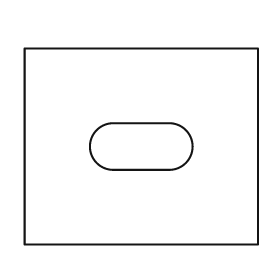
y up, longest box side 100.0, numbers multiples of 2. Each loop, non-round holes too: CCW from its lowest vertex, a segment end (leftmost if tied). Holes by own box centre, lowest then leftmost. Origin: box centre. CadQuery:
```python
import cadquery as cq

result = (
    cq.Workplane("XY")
    .moveTo(-50.0, -42.0)
    .lineTo(50.0, -42.0)
    .lineTo(50.0, 42.0)
    .lineTo(-50.0, 42.0)
    .close()
    .moveTo(-12.0, -10.0)
    .lineTo(12.0, -10.0)
    .threePointArc((22.0, 0.0), (12.0, 10.0))
    .lineTo(-12.0, 10.0)
    .threePointArc((-22.0, 0.0), (-12.0, -10.0))
    .close()
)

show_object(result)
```